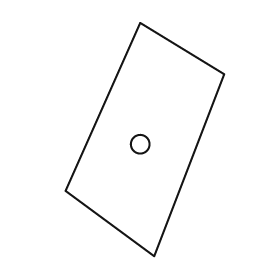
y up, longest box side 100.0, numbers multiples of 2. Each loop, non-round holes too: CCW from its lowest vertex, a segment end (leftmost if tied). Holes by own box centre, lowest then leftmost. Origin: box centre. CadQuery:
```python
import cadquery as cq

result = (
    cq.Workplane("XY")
    .moveTo(4.0, -50.0)
    .lineTo(34.0, 28.0)
    .lineTo(-2.0, 50.0)
    .lineTo(-34.0, -22.0)
    .close()
    .moveTo(-2.0, -2.0)
    .circle(4.0)
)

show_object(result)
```